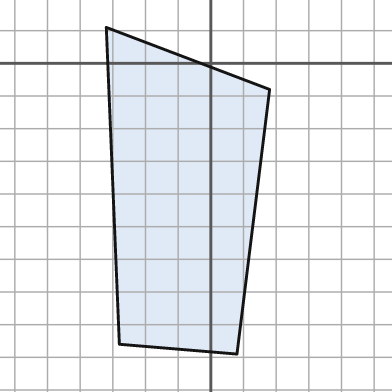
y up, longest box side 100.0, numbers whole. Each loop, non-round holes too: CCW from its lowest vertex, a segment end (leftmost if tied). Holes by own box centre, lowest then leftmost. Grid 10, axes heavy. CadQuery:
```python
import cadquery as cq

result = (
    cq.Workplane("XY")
    .moveTo(8.0, -89.0)
    .lineTo(18.0, -8.0)
    .lineTo(-32.0, 11.0)
    .lineTo(-28.0, -86.0)
    .close()
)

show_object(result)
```